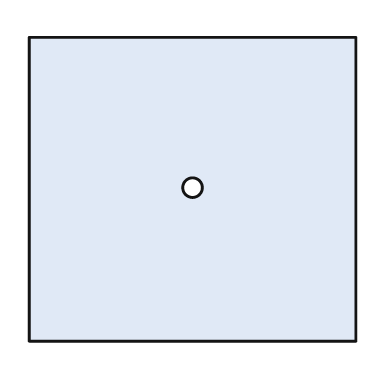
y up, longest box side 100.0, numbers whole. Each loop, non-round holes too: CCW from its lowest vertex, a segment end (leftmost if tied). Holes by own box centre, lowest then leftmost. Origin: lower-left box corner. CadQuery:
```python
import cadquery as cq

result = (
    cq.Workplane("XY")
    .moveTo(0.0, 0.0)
    .lineTo(100.0, 0.0)
    .lineTo(100.0, 93.0)
    .lineTo(0.0, 93.0)
    .close()
    .moveTo(50.0, 47.0)
    .circle(3.0)
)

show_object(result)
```